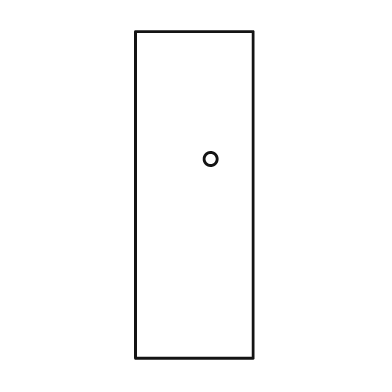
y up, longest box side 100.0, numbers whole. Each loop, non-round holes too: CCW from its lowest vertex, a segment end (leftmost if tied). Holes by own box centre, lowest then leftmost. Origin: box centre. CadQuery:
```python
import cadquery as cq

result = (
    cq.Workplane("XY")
    .moveTo(-18.0, -50.0)
    .lineTo(18.0, -50.0)
    .lineTo(18.0, 50.0)
    .lineTo(-18.0, 50.0)
    .close()
    .moveTo(5.0, 11.0)
    .circle(2.0)
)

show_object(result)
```